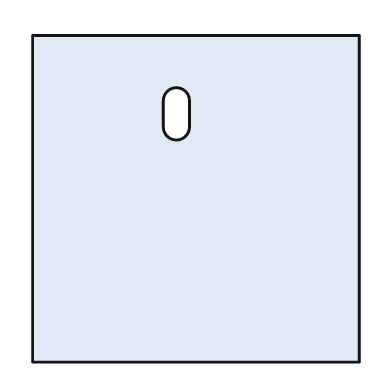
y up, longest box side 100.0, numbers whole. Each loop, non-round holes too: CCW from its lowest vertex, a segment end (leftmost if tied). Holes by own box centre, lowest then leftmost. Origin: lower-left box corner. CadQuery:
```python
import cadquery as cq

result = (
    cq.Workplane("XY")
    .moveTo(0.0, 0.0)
    .lineTo(100.0, 0.0)
    .lineTo(100.0, 100.0)
    .lineTo(0.0, 100.0)
    .close()
    .moveTo(40.0, 72.0)
    .threePointArc((44.0, 68.0), (48.0, 72.0))
    .lineTo(48.0, 80.0)
    .threePointArc((44.0, 84.0), (40.0, 80.0))
    .close()
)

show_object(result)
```